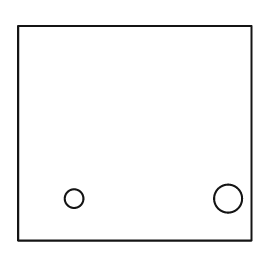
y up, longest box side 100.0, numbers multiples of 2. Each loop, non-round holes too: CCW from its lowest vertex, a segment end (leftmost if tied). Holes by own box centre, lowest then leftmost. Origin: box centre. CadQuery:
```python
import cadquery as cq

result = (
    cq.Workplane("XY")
    .moveTo(-50.0, -46.0)
    .lineTo(50.0, -46.0)
    .lineTo(50.0, 46.0)
    .lineTo(-50.0, 46.0)
    .close()
    .moveTo(-26.0, -28.0)
    .circle(4.0)
    .moveTo(40.0, -28.0)
    .circle(6.0)
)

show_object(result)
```